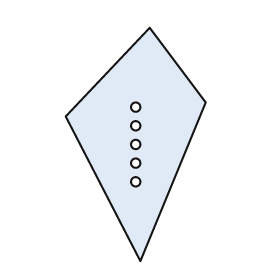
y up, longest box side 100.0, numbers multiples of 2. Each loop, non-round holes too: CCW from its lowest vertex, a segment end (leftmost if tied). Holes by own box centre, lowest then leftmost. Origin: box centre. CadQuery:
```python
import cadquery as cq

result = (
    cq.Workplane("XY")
    .moveTo(2.0, -50.0)
    .lineTo(30.0, 18.0)
    .lineTo(6.0, 50.0)
    .lineTo(-30.0, 12.0)
    .close()
    .moveTo(0.0, -16.0)
    .circle(2.0)
    .moveTo(0.0, -8.0)
    .circle(2.0)
    .moveTo(0.0, 0.0)
    .circle(2.0)
    .moveTo(0.0, 8.0)
    .circle(2.0)
    .moveTo(0.0, 16.0)
    .circle(2.0)
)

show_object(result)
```